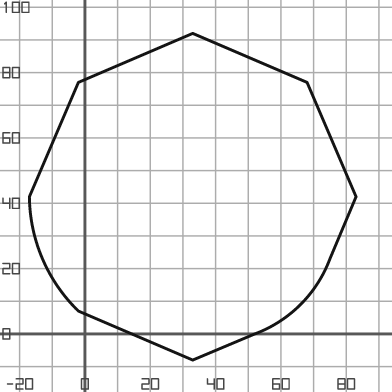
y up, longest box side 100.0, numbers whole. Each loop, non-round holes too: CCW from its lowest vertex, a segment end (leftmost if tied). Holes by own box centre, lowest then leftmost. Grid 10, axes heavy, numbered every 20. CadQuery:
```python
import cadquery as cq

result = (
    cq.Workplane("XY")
    .moveTo(33.0, -8.0)
    .lineTo(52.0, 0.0)
    .threePointArc((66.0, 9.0), (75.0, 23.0))
    .lineTo(83.0, 42.0)
    .lineTo(68.0, 77.0)
    .lineTo(33.0, 92.0)
    .lineTo(-2.0, 77.0)
    .lineTo(-17.0, 42.0)
    .threePointArc((-13.0, 23.0), (-2.0, 7.0))
    .close()
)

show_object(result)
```